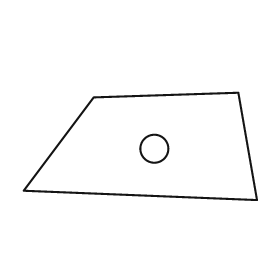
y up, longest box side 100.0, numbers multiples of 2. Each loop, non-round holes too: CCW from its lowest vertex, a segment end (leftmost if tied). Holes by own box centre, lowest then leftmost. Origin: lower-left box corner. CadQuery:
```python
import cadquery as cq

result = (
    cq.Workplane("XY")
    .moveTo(100.0, 0.0)
    .lineTo(92.0, 46.0)
    .lineTo(30.0, 44.0)
    .lineTo(0.0, 4.0)
    .close()
    .moveTo(56.0, 22.0)
    .circle(6.0)
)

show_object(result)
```